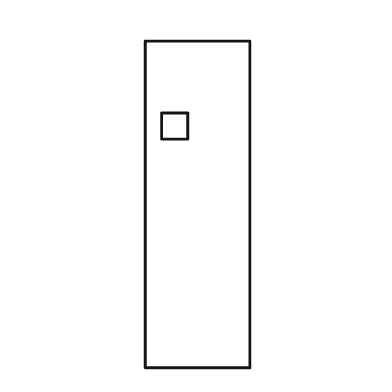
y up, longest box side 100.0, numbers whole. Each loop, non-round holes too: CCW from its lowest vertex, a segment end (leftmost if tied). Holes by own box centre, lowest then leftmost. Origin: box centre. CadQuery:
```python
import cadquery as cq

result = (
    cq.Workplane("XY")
    .moveTo(-16.0, -50.0)
    .lineTo(16.0, -50.0)
    .lineTo(16.0, 50.0)
    .lineTo(-16.0, 50.0)
    .close()
    .moveTo(-11.0, 20.0)
    .lineTo(-3.0, 20.0)
    .lineTo(-3.0, 28.0)
    .lineTo(-11.0, 28.0)
    .close()
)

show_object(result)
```